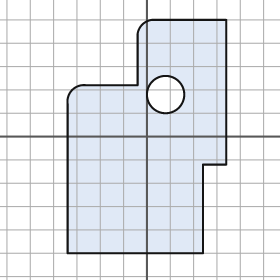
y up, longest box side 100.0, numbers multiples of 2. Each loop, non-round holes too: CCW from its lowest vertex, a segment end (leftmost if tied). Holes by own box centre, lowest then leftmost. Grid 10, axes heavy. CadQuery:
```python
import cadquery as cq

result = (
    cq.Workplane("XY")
    .moveTo(-34.0, -50.0)
    .lineTo(24.0, -50.0)
    .lineTo(24.0, -12.0)
    .lineTo(34.0, -12.0)
    .lineTo(34.0, 50.0)
    .lineTo(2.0, 50.0)
    .threePointArc((-2.0, 48.0), (-4.0, 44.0))
    .lineTo(-4.0, 22.0)
    .lineTo(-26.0, 22.0)
    .threePointArc((-32.0, 20.0), (-34.0, 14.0))
    .close()
    .moveTo(8.0, 18.0)
    .circle(8.0)
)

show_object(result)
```